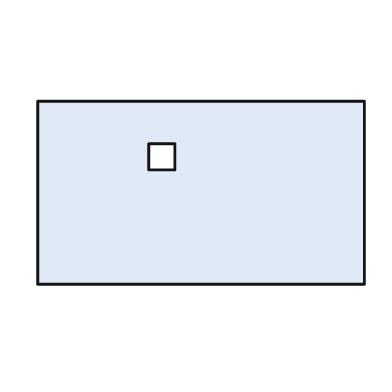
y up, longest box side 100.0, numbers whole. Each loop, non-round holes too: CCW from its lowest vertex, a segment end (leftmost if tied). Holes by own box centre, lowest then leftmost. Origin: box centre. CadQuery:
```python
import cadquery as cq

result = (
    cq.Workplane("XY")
    .moveTo(-50.0, -28.0)
    .lineTo(50.0, -28.0)
    .lineTo(50.0, 28.0)
    .lineTo(-50.0, 28.0)
    .close()
    .moveTo(-16.0, 7.0)
    .lineTo(-8.0, 7.0)
    .lineTo(-8.0, 15.0)
    .lineTo(-16.0, 15.0)
    .close()
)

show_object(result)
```